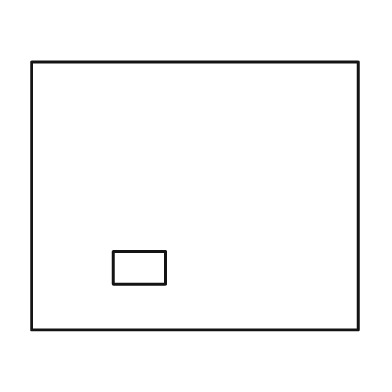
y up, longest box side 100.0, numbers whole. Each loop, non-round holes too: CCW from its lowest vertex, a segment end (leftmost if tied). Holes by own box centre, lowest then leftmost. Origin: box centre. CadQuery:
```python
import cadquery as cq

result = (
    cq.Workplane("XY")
    .moveTo(-50.0, -41.0)
    .lineTo(50.0, -41.0)
    .lineTo(50.0, 41.0)
    .lineTo(-50.0, 41.0)
    .close()
    .moveTo(-25.0, -27.0)
    .lineTo(-9.0, -27.0)
    .lineTo(-9.0, -17.0)
    .lineTo(-25.0, -17.0)
    .close()
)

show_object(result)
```